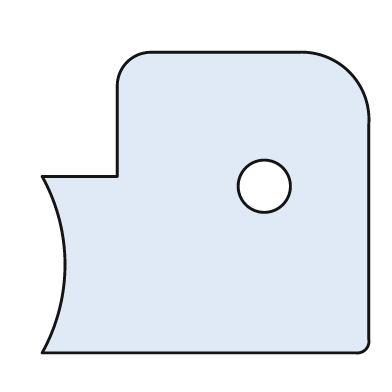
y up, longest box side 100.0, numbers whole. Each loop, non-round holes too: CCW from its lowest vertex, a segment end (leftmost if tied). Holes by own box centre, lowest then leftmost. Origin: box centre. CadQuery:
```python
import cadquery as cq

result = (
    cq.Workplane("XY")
    .moveTo(-50.0, -46.0)
    .lineTo(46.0, -46.0)
    .threePointArc((49.0, -45.0), (50.0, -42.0))
    .lineTo(50.0, 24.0)
    .threePointArc((44.0, 40.0), (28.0, 46.0))
    .lineTo(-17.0, 46.0)
    .threePointArc((-24.0, 43.0), (-27.0, 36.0))
    .lineTo(-27.0, 8.0)
    .lineTo(-50.0, 8.0)
    .threePointArc((-43.0, -19.0), (-50.0, -46.0))
    .close()
    .moveTo(18.0, 5.0)
    .circle(8.0)
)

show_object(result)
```